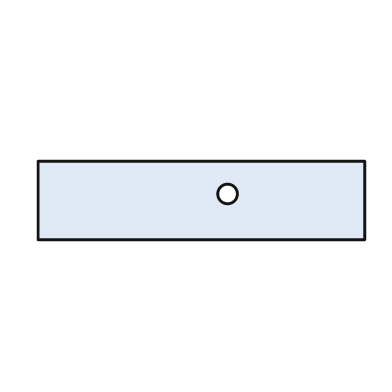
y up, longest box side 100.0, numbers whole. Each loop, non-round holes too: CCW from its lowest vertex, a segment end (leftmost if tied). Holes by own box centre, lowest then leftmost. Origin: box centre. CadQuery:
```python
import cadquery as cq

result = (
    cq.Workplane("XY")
    .moveTo(-50.0, -12.0)
    .lineTo(50.0, -12.0)
    .lineTo(50.0, 12.0)
    .lineTo(-50.0, 12.0)
    .close()
    .moveTo(8.0, 2.0)
    .circle(3.0)
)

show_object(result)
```